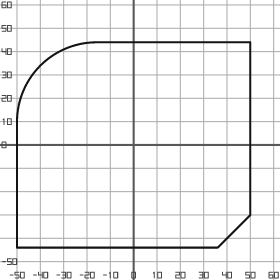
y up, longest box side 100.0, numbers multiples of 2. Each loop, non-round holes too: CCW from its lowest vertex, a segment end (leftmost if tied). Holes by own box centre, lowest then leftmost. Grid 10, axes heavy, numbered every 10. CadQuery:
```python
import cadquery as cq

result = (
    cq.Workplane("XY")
    .moveTo(-50.0, -44.0)
    .lineTo(36.0, -44.0)
    .lineTo(50.0, -30.0)
    .lineTo(50.0, 44.0)
    .lineTo(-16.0, 44.0)
    .threePointArc((-40.0, 34.0), (-50.0, 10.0))
    .close()
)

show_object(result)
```